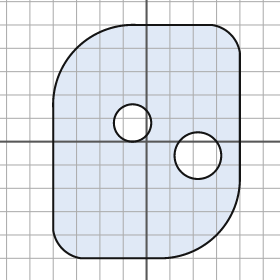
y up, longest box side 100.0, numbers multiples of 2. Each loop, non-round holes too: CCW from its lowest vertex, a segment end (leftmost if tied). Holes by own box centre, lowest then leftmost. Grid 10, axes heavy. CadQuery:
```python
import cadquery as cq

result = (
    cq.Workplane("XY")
    .moveTo(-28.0, -50.0)
    .lineTo(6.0, -50.0)
    .threePointArc((30.0, -40.0), (40.0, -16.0))
    .lineTo(40.0, 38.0)
    .threePointArc((36.0, 46.0), (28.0, 50.0))
    .lineTo(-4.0, 50.0)
    .threePointArc((-30.0, 40.0), (-40.0, 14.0))
    .lineTo(-40.0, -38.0)
    .threePointArc((-36.0, -46.0), (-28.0, -50.0))
    .close()
    .moveTo(22.0, -6.0)
    .circle(10.0)
    .moveTo(-6.0, 8.0)
    .circle(8.0)
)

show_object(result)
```